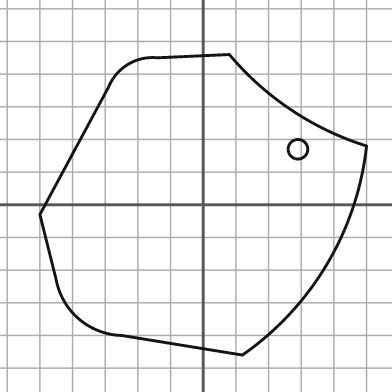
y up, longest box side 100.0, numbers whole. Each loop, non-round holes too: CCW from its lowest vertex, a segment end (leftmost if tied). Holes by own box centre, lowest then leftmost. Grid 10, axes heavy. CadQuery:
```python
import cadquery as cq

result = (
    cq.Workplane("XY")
    .moveTo(12.0, -46.0)
    .threePointArc((38.0, -18.0), (50.0, 18.0))
    .threePointArc((27.0, 29.0), (8.0, 46.0))
    .lineTo(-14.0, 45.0)
    .threePointArc((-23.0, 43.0), (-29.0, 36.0))
    .lineTo(-50.0, -3.0)
    .lineTo(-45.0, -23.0)
    .threePointArc((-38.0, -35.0), (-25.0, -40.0))
    .close()
    .moveTo(29.0, 17.0)
    .circle(3.0)
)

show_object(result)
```